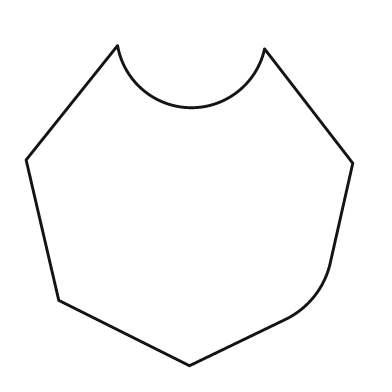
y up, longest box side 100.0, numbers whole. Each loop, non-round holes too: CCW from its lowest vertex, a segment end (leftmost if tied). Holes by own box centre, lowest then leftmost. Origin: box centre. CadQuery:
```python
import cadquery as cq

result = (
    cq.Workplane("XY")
    .moveTo(0.0, -49.0)
    .lineTo(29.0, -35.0)
    .threePointArc((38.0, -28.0), (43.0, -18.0))
    .lineTo(50.0, 13.0)
    .lineTo(23.0, 48.0)
    .threePointArc((0.0, 30.0), (-22.0, 49.0))
    .lineTo(-50.0, 14.0)
    .lineTo(-40.0, -29.0)
    .close()
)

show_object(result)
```